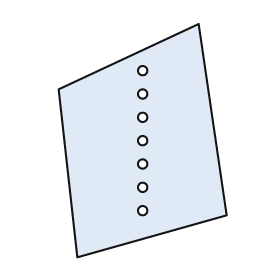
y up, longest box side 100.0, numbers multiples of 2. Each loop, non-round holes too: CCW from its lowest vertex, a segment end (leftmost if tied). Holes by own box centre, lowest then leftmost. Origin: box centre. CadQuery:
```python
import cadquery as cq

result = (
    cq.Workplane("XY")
    .moveTo(-28.0, -50.0)
    .lineTo(36.0, -32.0)
    .lineTo(24.0, 50.0)
    .lineTo(-36.0, 22.0)
    .close()
    .moveTo(0.0, -30.0)
    .circle(2.0)
    .moveTo(0.0, -20.0)
    .circle(2.0)
    .moveTo(0.0, -10.0)
    .circle(2.0)
    .moveTo(0.0, 0.0)
    .circle(2.0)
    .moveTo(0.0, 10.0)
    .circle(2.0)
    .moveTo(0.0, 20.0)
    .circle(2.0)
    .moveTo(0.0, 30.0)
    .circle(2.0)
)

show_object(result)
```